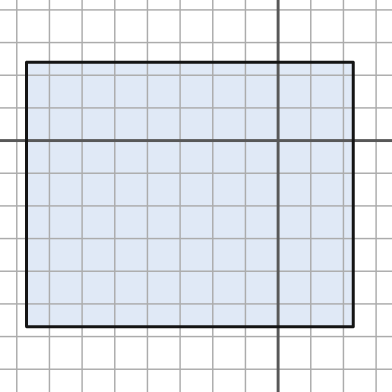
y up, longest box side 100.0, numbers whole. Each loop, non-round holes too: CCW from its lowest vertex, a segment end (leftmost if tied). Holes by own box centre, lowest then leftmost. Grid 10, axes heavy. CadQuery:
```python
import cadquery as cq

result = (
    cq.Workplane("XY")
    .moveTo(-77.0, -57.0)
    .lineTo(23.0, -57.0)
    .lineTo(23.0, 24.0)
    .lineTo(-77.0, 24.0)
    .close()
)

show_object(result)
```